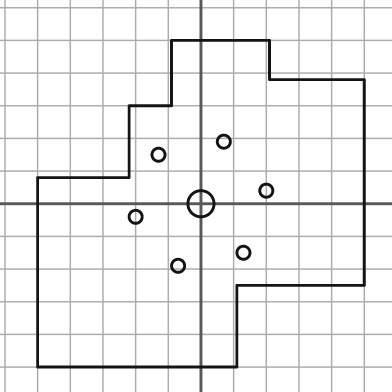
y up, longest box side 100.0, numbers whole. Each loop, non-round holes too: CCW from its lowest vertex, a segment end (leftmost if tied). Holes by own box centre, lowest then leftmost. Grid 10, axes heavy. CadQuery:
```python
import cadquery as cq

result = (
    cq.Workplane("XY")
    .moveTo(-50.0, -50.0)
    .lineTo(11.0, -50.0)
    .lineTo(11.0, -25.0)
    .lineTo(50.0, -25.0)
    .lineTo(50.0, 38.0)
    .lineTo(21.0, 38.0)
    .lineTo(21.0, 50.0)
    .lineTo(-9.0, 50.0)
    .lineTo(-9.0, 30.0)
    .lineTo(-22.0, 30.0)
    .lineTo(-22.0, 8.0)
    .lineTo(-50.0, 8.0)
    .close()
    .moveTo(-7.0, -19.0)
    .circle(2.0)
    .moveTo(13.0, -15.0)
    .circle(2.0)
    .moveTo(-20.0, -4.0)
    .circle(2.0)
    .moveTo(0.0, 0.0)
    .circle(4.0)
    .moveTo(20.0, 4.0)
    .circle(2.0)
    .moveTo(-13.0, 15.0)
    .circle(2.0)
    .moveTo(7.0, 19.0)
    .circle(2.0)
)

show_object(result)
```